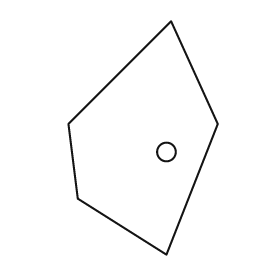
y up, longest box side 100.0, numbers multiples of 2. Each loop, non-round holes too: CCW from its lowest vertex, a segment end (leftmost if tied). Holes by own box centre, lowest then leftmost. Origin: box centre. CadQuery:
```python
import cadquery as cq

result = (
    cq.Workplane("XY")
    .moveTo(10.0, -50.0)
    .lineTo(32.0, 6.0)
    .lineTo(12.0, 50.0)
    .lineTo(-32.0, 6.0)
    .lineTo(-28.0, -26.0)
    .close()
    .moveTo(10.0, -6.0)
    .circle(4.0)
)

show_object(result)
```